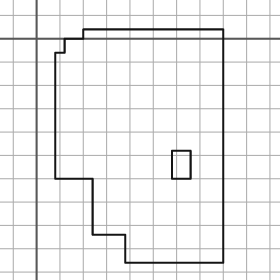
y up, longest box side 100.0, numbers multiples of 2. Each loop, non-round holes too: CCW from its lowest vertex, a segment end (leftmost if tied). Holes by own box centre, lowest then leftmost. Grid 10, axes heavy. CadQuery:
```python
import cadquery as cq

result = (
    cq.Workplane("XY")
    .moveTo(38.0, -96.0)
    .lineTo(80.0, -96.0)
    .lineTo(80.0, 4.0)
    .lineTo(20.0, 4.0)
    .lineTo(20.0, 0.0)
    .lineTo(12.0, 0.0)
    .lineTo(12.0, -6.0)
    .lineTo(8.0, -6.0)
    .lineTo(8.0, -60.0)
    .lineTo(24.0, -60.0)
    .lineTo(24.0, -84.0)
    .lineTo(38.0, -84.0)
    .close()
    .moveTo(58.0, -60.0)
    .lineTo(66.0, -60.0)
    .lineTo(66.0, -48.0)
    .lineTo(58.0, -48.0)
    .close()
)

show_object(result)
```